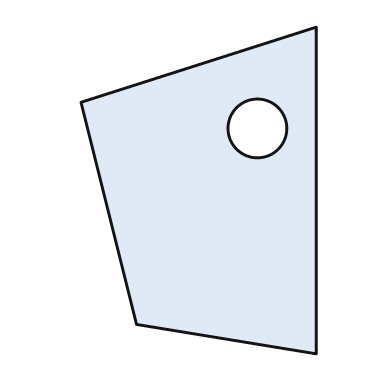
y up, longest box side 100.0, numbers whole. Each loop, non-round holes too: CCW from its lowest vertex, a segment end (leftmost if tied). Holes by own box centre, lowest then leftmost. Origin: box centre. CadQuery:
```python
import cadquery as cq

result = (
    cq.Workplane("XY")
    .moveTo(36.0, -50.0)
    .lineTo(36.0, 50.0)
    .lineTo(-36.0, 27.0)
    .lineTo(-19.0, -41.0)
    .close()
    .moveTo(18.0, 19.0)
    .circle(9.0)
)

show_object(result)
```